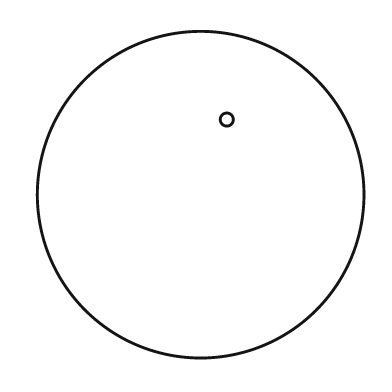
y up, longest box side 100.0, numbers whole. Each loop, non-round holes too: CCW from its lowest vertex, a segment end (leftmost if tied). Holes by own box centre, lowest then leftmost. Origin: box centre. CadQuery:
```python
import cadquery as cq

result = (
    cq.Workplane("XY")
    .moveTo(0.0, 0.0)
    .circle(50.0)
    .moveTo(8.0, 23.0)
    .circle(2.0)
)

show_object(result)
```